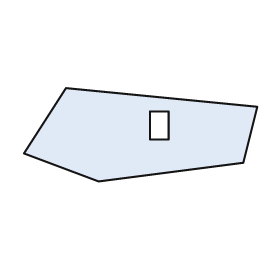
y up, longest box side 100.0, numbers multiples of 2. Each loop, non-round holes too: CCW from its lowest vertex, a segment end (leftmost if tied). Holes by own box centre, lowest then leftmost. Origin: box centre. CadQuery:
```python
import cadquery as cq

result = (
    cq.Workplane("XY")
    .moveTo(-18.0, -20.0)
    .lineTo(44.0, -12.0)
    .lineTo(50.0, 12.0)
    .lineTo(-32.0, 20.0)
    .lineTo(-50.0, -8.0)
    .close()
    .moveTo(4.0, -2.0)
    .lineTo(12.0, -2.0)
    .lineTo(12.0, 10.0)
    .lineTo(4.0, 10.0)
    .close()
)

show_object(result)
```